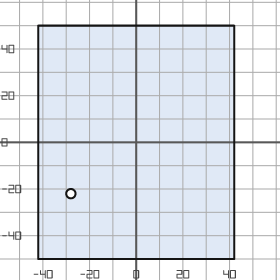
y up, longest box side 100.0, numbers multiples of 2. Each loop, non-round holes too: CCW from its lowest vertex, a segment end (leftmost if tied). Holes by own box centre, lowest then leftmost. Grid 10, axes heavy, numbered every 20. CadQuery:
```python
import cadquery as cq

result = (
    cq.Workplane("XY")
    .moveTo(-42.0, -50.0)
    .lineTo(42.0, -50.0)
    .lineTo(42.0, 50.0)
    .lineTo(-42.0, 50.0)
    .close()
    .moveTo(-28.0, -22.0)
    .circle(2.0)
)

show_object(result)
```